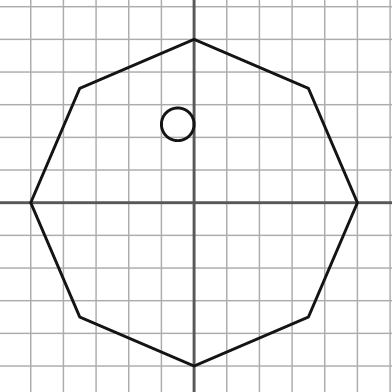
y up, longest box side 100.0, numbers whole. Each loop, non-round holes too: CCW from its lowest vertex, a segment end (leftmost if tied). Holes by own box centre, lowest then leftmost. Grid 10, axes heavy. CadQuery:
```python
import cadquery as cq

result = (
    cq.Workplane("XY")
    .moveTo(0.0, -50.0)
    .lineTo(35.0, -35.0)
    .lineTo(50.0, 0.0)
    .lineTo(35.0, 35.0)
    .lineTo(0.0, 50.0)
    .lineTo(-35.0, 35.0)
    .lineTo(-50.0, 0.0)
    .lineTo(-35.0, -35.0)
    .close()
    .moveTo(-5.0, 24.0)
    .circle(5.0)
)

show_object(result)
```